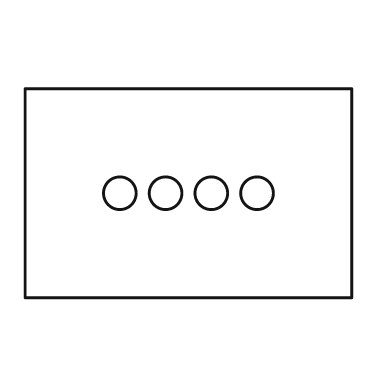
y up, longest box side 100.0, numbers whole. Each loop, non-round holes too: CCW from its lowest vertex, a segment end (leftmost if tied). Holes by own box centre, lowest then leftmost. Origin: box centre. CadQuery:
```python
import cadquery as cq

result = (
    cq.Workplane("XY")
    .moveTo(-50.0, -32.0)
    .lineTo(50.0, -32.0)
    .lineTo(50.0, 32.0)
    .lineTo(-50.0, 32.0)
    .close()
    .moveTo(-21.0, 0.0)
    .circle(5.0)
    .moveTo(-7.0, 0.0)
    .circle(5.0)
    .moveTo(7.0, 0.0)
    .circle(5.0)
    .moveTo(21.0, 0.0)
    .circle(5.0)
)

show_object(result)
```